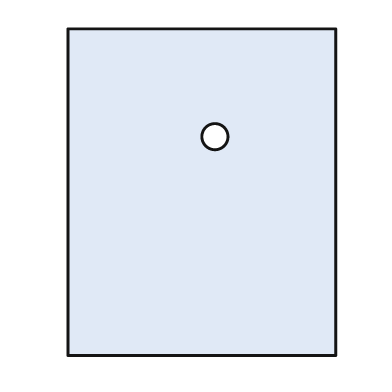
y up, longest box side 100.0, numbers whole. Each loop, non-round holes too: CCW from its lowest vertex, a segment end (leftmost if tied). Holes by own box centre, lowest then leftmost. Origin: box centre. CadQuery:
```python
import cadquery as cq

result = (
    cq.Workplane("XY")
    .moveTo(-41.0, -50.0)
    .lineTo(41.0, -50.0)
    .lineTo(41.0, 50.0)
    .lineTo(-41.0, 50.0)
    .close()
    .moveTo(4.0, 17.0)
    .circle(4.0)
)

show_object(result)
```